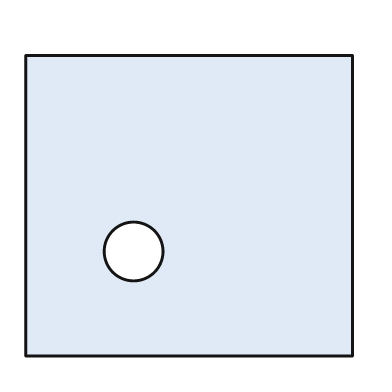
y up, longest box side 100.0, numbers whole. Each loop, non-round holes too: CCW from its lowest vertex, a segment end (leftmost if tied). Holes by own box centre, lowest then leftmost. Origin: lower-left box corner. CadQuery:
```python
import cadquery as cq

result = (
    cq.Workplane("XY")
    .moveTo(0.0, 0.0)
    .lineTo(100.0, 0.0)
    .lineTo(100.0, 92.0)
    .lineTo(0.0, 92.0)
    .close()
    .moveTo(33.0, 32.0)
    .circle(9.0)
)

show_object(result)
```